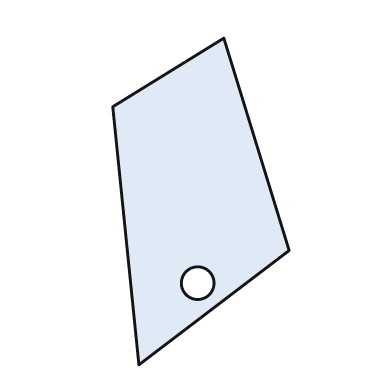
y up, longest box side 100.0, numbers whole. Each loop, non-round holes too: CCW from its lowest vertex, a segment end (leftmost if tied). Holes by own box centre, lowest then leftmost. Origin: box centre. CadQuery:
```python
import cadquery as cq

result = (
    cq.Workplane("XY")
    .moveTo(-19.0, -50.0)
    .lineTo(27.0, -15.0)
    .lineTo(7.0, 50.0)
    .lineTo(-27.0, 29.0)
    .close()
    .moveTo(-1.0, -25.0)
    .circle(5.0)
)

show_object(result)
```